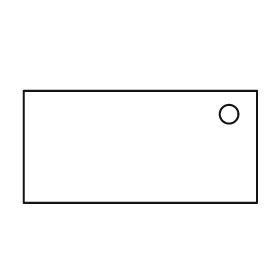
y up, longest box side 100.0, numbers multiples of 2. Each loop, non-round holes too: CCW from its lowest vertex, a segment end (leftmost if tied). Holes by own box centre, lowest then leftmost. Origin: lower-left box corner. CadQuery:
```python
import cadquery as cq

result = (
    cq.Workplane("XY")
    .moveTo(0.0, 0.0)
    .lineTo(100.0, 0.0)
    .lineTo(100.0, 48.0)
    .lineTo(0.0, 48.0)
    .close()
    .moveTo(88.0, 38.0)
    .circle(4.0)
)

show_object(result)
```